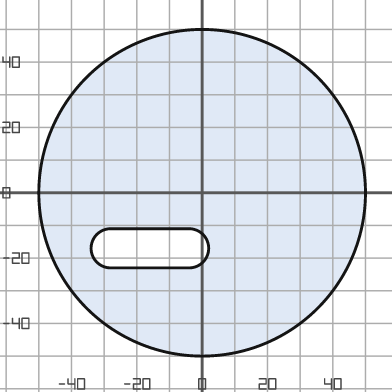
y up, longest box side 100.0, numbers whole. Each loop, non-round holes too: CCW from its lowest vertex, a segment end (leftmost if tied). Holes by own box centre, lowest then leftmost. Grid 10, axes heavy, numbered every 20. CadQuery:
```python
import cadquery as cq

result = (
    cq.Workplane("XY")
    .moveTo(0.0, 0.0)
    .circle(50.0)
    .moveTo(-28.0, -23.0)
    .lineTo(-4.0, -23.0)
    .threePointArc((2.0, -17.0), (-4.0, -11.0))
    .lineTo(-28.0, -11.0)
    .threePointArc((-34.0, -17.0), (-28.0, -23.0))
    .close()
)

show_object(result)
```